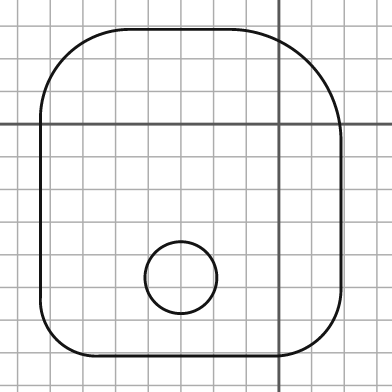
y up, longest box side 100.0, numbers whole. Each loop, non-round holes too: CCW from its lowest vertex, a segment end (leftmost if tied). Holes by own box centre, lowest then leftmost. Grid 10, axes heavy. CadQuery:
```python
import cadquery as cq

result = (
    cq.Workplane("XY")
    .moveTo(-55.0, -71.0)
    .lineTo(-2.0, -71.0)
    .threePointArc((13.0, -65.0), (19.0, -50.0))
    .lineTo(19.0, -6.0)
    .threePointArc((9.0, 19.0), (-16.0, 29.0))
    .lineTo(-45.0, 29.0)
    .threePointArc((-65.0, 21.0), (-73.0, 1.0))
    .lineTo(-73.0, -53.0)
    .threePointArc((-68.0, -66.0), (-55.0, -71.0))
    .close()
    .moveTo(-30.0, -47.0)
    .circle(11.0)
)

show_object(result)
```